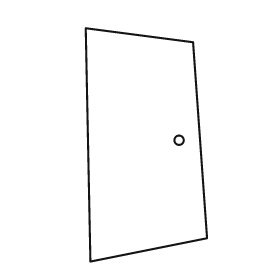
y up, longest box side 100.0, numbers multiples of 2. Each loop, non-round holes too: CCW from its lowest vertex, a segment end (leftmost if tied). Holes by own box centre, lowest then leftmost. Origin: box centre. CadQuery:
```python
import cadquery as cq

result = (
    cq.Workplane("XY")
    .moveTo(-24.0, -50.0)
    .lineTo(26.0, -40.0)
    .lineTo(20.0, 44.0)
    .lineTo(-26.0, 50.0)
    .close()
    .moveTo(14.0, 2.0)
    .circle(2.0)
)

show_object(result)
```